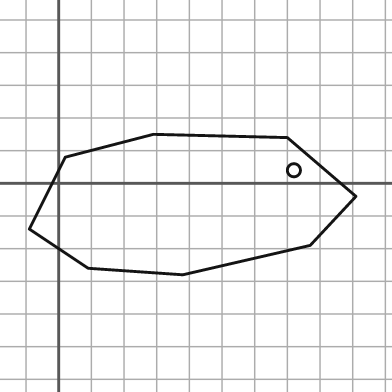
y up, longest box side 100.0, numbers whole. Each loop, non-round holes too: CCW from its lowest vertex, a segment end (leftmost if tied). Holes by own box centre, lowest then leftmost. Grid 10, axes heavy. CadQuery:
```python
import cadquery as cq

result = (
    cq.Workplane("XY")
    .moveTo(38.0, -28.0)
    .lineTo(77.0, -19.0)
    .lineTo(91.0, -4.0)
    .lineTo(70.0, 14.0)
    .lineTo(29.0, 15.0)
    .lineTo(2.0, 8.0)
    .lineTo(-9.0, -14.0)
    .lineTo(9.0, -26.0)
    .close()
    .moveTo(72.0, 4.0)
    .circle(2.0)
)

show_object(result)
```